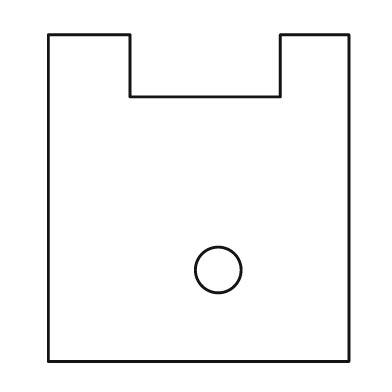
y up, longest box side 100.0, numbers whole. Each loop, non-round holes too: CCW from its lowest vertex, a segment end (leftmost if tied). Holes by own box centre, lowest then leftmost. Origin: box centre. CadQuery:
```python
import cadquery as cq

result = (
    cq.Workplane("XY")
    .moveTo(-46.0, -50.0)
    .lineTo(46.0, -50.0)
    .lineTo(46.0, 50.0)
    .lineTo(25.0, 50.0)
    .lineTo(25.0, 31.0)
    .lineTo(-21.0, 31.0)
    .lineTo(-21.0, 50.0)
    .lineTo(-46.0, 50.0)
    .close()
    .moveTo(6.0, -22.0)
    .circle(7.0)
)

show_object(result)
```